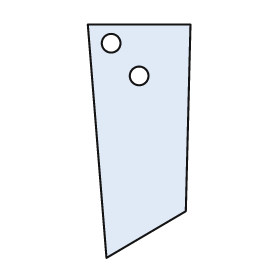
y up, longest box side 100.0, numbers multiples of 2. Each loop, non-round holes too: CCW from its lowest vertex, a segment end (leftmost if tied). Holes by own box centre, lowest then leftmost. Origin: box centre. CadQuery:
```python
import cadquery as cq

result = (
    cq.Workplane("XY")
    .moveTo(-14.0, -50.0)
    .lineTo(20.0, -30.0)
    .lineTo(22.0, 50.0)
    .lineTo(-22.0, 50.0)
    .close()
    .moveTo(0.0, 28.0)
    .circle(4.0)
    .moveTo(-12.0, 42.0)
    .circle(4.0)
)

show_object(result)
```